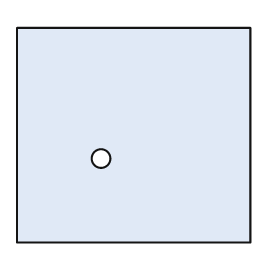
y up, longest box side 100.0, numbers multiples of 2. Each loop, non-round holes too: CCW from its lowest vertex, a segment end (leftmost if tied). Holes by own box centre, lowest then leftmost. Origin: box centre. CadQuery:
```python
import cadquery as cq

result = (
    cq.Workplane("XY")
    .moveTo(-50.0, -46.0)
    .lineTo(50.0, -46.0)
    .lineTo(50.0, 46.0)
    .lineTo(-50.0, 46.0)
    .close()
    .moveTo(-14.0, -10.0)
    .circle(4.0)
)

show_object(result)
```